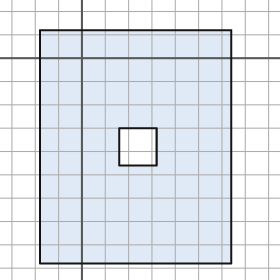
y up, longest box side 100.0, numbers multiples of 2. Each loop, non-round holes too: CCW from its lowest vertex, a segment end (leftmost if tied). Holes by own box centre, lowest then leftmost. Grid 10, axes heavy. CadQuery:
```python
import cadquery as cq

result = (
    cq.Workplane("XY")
    .moveTo(-18.0, -88.0)
    .lineTo(64.0, -88.0)
    .lineTo(64.0, 12.0)
    .lineTo(-18.0, 12.0)
    .close()
    .moveTo(16.0, -46.0)
    .lineTo(32.0, -46.0)
    .lineTo(32.0, -30.0)
    .lineTo(16.0, -30.0)
    .close()
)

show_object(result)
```